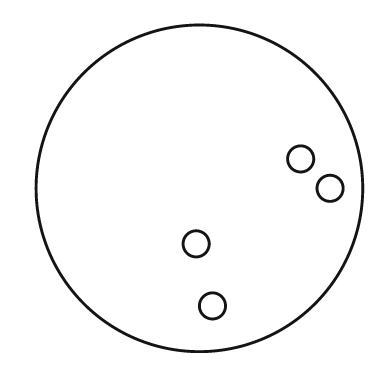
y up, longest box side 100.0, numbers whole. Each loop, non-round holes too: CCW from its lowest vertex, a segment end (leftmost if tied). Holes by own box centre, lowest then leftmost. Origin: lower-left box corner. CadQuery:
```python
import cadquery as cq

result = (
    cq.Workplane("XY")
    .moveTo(50.0, 50.0)
    .circle(50.0)
    .moveTo(54.0, 14.0)
    .circle(4.0)
    .moveTo(49.0, 33.0)
    .circle(4.0)
    .moveTo(90.0, 50.0)
    .circle(4.0)
    .moveTo(81.0, 59.0)
    .circle(4.0)
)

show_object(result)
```